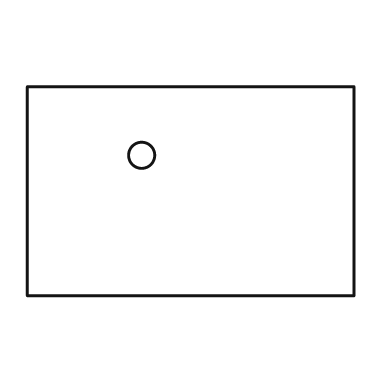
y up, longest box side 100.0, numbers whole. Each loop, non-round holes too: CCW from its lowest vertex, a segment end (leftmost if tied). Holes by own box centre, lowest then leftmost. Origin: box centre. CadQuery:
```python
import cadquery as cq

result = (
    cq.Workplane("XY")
    .moveTo(-50.0, -32.0)
    .lineTo(50.0, -32.0)
    .lineTo(50.0, 32.0)
    .lineTo(-50.0, 32.0)
    .close()
    .moveTo(-15.0, 11.0)
    .circle(4.0)
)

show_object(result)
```